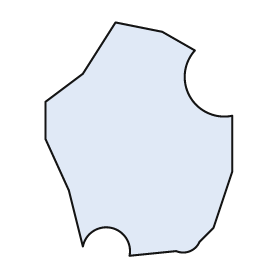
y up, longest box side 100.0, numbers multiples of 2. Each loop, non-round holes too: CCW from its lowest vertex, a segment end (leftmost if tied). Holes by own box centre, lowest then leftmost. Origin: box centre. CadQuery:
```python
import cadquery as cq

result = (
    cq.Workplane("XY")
    .moveTo(-4.0, -50.0)
    .lineTo(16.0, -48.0)
    .threePointArc((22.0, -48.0), (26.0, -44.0))
    .lineTo(32.0, -38.0)
    .lineTo(40.0, -14.0)
    .lineTo(40.0, 10.0)
    .threePointArc((22.0, 18.0), (24.0, 38.0))
    .lineTo(10.0, 46.0)
    .lineTo(-10.0, 50.0)
    .lineTo(-24.0, 28.0)
    .lineTo(-40.0, 16.0)
    .lineTo(-40.0, 0.0)
    .lineTo(-30.0, -22.0)
    .lineTo(-24.0, -46.0)
    .threePointArc((-12.0, -38.0), (-4.0, -50.0))
    .close()
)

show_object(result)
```